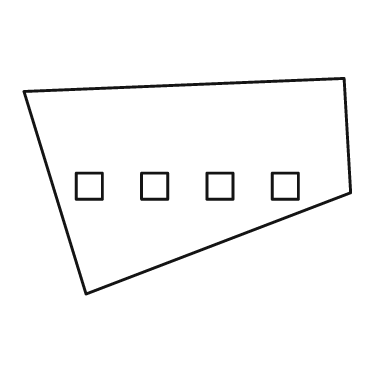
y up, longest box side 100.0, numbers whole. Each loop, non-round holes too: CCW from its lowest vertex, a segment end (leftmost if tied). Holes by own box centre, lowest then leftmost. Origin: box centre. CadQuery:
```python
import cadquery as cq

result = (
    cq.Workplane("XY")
    .moveTo(-31.0, -33.0)
    .lineTo(50.0, -2.0)
    .lineTo(48.0, 33.0)
    .lineTo(-50.0, 29.0)
    .close()
    .moveTo(-34.0, -4.0)
    .lineTo(-26.0, -4.0)
    .lineTo(-26.0, 4.0)
    .lineTo(-34.0, 4.0)
    .close()
    .moveTo(-14.0, -4.0)
    .lineTo(-6.0, -4.0)
    .lineTo(-6.0, 4.0)
    .lineTo(-14.0, 4.0)
    .close()
    .moveTo(6.0, -4.0)
    .lineTo(14.0, -4.0)
    .lineTo(14.0, 4.0)
    .lineTo(6.0, 4.0)
    .close()
    .moveTo(26.0, -4.0)
    .lineTo(34.0, -4.0)
    .lineTo(34.0, 4.0)
    .lineTo(26.0, 4.0)
    .close()
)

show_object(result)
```